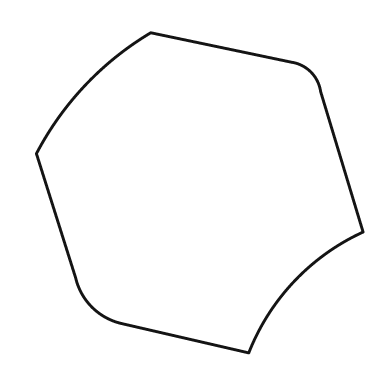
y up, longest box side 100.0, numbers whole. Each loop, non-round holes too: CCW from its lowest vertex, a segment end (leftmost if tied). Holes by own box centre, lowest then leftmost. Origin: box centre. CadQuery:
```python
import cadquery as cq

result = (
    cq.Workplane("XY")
    .moveTo(15.0, -49.0)
    .threePointArc((29.0, -27.0), (50.0, -12.0))
    .lineTo(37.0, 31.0)
    .threePointArc((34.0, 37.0), (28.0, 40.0))
    .lineTo(-15.0, 49.0)
    .threePointArc((-35.0, 33.0), (-50.0, 12.0))
    .lineTo(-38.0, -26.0)
    .threePointArc((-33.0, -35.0), (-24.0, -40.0))
    .close()
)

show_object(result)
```